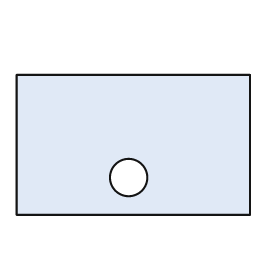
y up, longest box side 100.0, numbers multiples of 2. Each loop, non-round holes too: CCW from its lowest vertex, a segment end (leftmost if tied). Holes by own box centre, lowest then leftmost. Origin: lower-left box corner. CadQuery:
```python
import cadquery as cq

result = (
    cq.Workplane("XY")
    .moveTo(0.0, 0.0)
    .lineTo(100.0, 0.0)
    .lineTo(100.0, 60.0)
    .lineTo(0.0, 60.0)
    .close()
    .moveTo(48.0, 16.0)
    .circle(8.0)
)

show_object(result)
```